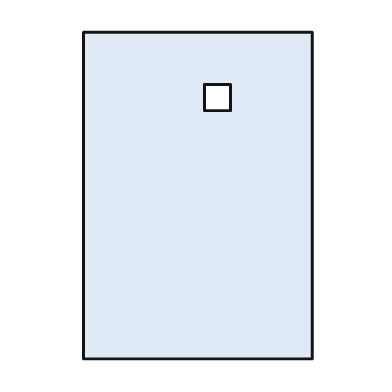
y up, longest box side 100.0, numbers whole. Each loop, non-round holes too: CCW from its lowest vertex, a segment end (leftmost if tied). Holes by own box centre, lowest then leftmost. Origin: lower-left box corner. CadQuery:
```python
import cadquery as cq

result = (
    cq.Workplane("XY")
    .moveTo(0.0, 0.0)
    .lineTo(70.0, 0.0)
    .lineTo(70.0, 100.0)
    .lineTo(0.0, 100.0)
    .close()
    .moveTo(37.0, 76.0)
    .lineTo(45.0, 76.0)
    .lineTo(45.0, 84.0)
    .lineTo(37.0, 84.0)
    .close()
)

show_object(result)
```